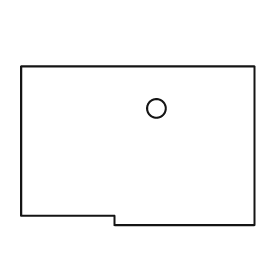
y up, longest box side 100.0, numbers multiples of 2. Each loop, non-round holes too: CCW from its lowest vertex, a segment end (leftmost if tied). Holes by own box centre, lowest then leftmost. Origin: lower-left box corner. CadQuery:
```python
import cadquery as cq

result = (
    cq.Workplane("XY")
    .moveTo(40.0, 0.0)
    .lineTo(100.0, 0.0)
    .lineTo(100.0, 68.0)
    .lineTo(0.0, 68.0)
    .lineTo(0.0, 4.0)
    .lineTo(40.0, 4.0)
    .close()
    .moveTo(58.0, 50.0)
    .circle(4.0)
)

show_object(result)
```